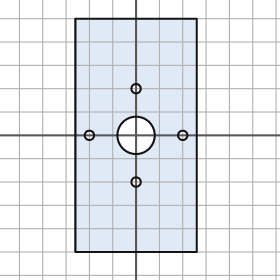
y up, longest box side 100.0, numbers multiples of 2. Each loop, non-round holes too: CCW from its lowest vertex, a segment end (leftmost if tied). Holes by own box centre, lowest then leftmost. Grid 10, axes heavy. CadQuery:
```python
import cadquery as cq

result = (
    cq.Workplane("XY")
    .moveTo(-26.0, -50.0)
    .lineTo(26.0, -50.0)
    .lineTo(26.0, 50.0)
    .lineTo(-26.0, 50.0)
    .close()
    .moveTo(0.0, -20.0)
    .circle(2.0)
    .moveTo(-20.0, 0.0)
    .circle(2.0)
    .moveTo(0.0, 0.0)
    .circle(8.0)
    .moveTo(20.0, 0.0)
    .circle(2.0)
    .moveTo(0.0, 20.0)
    .circle(2.0)
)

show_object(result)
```